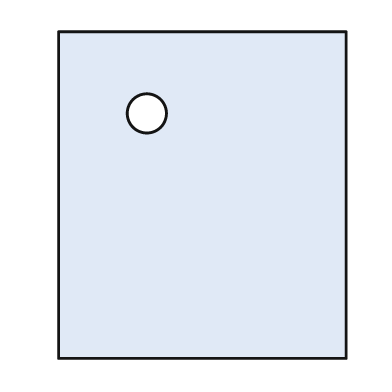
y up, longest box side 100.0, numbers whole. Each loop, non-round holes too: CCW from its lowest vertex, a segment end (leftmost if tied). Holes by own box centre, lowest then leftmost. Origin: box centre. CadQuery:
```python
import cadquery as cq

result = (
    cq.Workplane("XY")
    .moveTo(-44.0, -50.0)
    .lineTo(44.0, -50.0)
    .lineTo(44.0, 50.0)
    .lineTo(-44.0, 50.0)
    .close()
    .moveTo(-17.0, 25.0)
    .circle(6.0)
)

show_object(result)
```